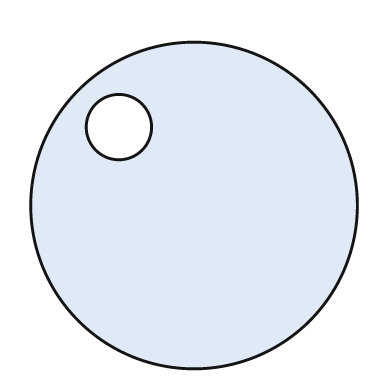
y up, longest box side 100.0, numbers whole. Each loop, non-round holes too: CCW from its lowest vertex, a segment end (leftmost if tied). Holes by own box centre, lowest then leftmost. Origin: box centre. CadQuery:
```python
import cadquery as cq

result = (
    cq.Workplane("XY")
    .moveTo(0.0, 0.0)
    .circle(50.0)
    .moveTo(-23.0, 24.0)
    .circle(10.0)
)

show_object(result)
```